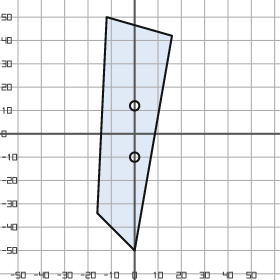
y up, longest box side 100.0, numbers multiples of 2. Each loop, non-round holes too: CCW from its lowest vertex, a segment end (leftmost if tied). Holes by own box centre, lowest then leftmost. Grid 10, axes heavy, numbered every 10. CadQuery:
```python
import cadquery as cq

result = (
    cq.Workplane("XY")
    .moveTo(0.0, -50.0)
    .lineTo(16.0, 42.0)
    .lineTo(-12.0, 50.0)
    .lineTo(-16.0, -34.0)
    .close()
    .moveTo(0.0, -10.0)
    .circle(2.0)
    .moveTo(0.0, 12.0)
    .circle(2.0)
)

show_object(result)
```